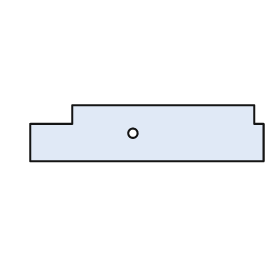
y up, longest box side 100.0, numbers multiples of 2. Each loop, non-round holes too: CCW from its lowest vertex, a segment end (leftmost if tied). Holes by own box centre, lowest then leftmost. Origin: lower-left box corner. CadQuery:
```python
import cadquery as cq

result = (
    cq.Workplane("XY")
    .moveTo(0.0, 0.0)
    .lineTo(100.0, 0.0)
    .lineTo(100.0, 16.0)
    .lineTo(96.0, 16.0)
    .lineTo(96.0, 24.0)
    .lineTo(18.0, 24.0)
    .lineTo(18.0, 16.0)
    .lineTo(0.0, 16.0)
    .close()
    .moveTo(44.0, 12.0)
    .circle(2.0)
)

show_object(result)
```